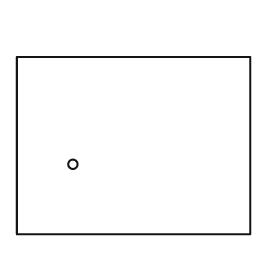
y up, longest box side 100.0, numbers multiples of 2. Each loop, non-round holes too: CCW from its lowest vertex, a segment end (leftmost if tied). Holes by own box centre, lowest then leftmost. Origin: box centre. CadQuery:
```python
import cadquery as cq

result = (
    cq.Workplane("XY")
    .moveTo(-50.0, -38.0)
    .lineTo(50.0, -38.0)
    .lineTo(50.0, 38.0)
    .lineTo(-50.0, 38.0)
    .close()
    .moveTo(-26.0, -8.0)
    .circle(2.0)
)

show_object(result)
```